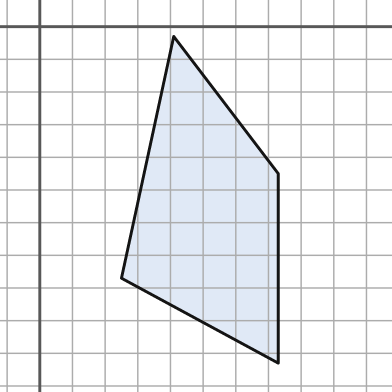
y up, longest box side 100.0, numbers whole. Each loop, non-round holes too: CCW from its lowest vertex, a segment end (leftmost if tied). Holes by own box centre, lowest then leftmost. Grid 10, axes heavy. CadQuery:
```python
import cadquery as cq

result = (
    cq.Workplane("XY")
    .moveTo(73.0, -103.0)
    .lineTo(73.0, -45.0)
    .lineTo(41.0, -3.0)
    .lineTo(25.0, -77.0)
    .close()
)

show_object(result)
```